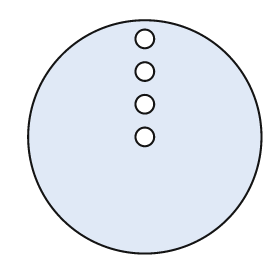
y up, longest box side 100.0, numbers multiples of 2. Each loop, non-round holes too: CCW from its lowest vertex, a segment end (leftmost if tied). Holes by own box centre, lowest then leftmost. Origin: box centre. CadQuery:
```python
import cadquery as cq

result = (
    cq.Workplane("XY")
    .moveTo(0.0, 0.0)
    .circle(50.0)
    .moveTo(0.0, 0.0)
    .circle(4.0)
    .moveTo(0.0, 14.0)
    .circle(4.0)
    .moveTo(0.0, 28.0)
    .circle(4.0)
    .moveTo(0.0, 42.0)
    .circle(4.0)
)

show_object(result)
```